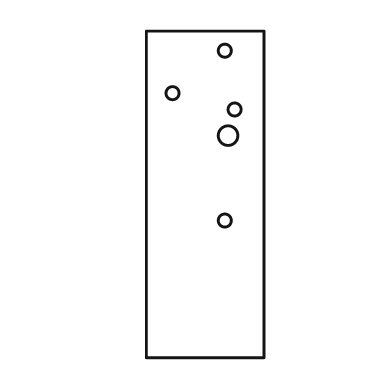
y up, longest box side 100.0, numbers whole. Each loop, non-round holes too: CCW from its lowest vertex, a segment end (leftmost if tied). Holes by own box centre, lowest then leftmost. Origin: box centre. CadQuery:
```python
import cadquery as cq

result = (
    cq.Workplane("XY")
    .moveTo(-18.0, -50.0)
    .lineTo(18.0, -50.0)
    .lineTo(18.0, 50.0)
    .lineTo(-18.0, 50.0)
    .close()
    .moveTo(6.0, -8.0)
    .circle(2.0)
    .moveTo(7.0, 18.0)
    .circle(3.0)
    .moveTo(9.0, 26.0)
    .circle(2.0)
    .moveTo(-10.0, 31.0)
    .circle(2.0)
    .moveTo(6.0, 44.0)
    .circle(2.0)
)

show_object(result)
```